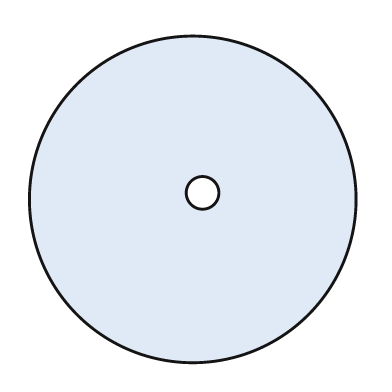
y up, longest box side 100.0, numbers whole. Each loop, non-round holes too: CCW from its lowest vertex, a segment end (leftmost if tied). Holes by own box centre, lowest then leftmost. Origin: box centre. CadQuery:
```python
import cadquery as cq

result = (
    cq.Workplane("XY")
    .moveTo(0.0, 0.0)
    .circle(50.0)
    .moveTo(3.0, 2.0)
    .circle(5.0)
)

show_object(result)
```